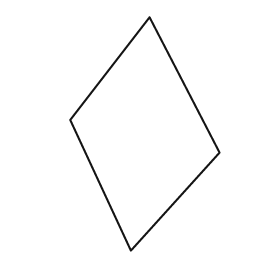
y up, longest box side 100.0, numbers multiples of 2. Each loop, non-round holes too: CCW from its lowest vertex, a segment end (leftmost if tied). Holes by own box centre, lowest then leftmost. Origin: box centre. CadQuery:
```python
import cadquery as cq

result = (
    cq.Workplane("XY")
    .moveTo(-6.0, -50.0)
    .lineTo(32.0, -8.0)
    .lineTo(2.0, 50.0)
    .lineTo(-32.0, 6.0)
    .close()
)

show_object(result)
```